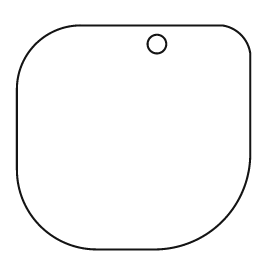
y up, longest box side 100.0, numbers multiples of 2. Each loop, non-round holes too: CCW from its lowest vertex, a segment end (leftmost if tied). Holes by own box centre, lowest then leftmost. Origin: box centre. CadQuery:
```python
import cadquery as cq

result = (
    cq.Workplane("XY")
    .moveTo(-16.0, -48.0)
    .lineTo(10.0, -48.0)
    .threePointArc((38.0, -36.0), (50.0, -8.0))
    .lineTo(50.0, 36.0)
    .threePointArc((46.0, 44.0), (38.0, 48.0))
    .lineTo(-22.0, 48.0)
    .threePointArc((-42.0, 40.0), (-50.0, 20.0))
    .lineTo(-50.0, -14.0)
    .threePointArc((-40.0, -38.0), (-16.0, -48.0))
    .close()
    .moveTo(10.0, 40.0)
    .circle(4.0)
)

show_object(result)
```